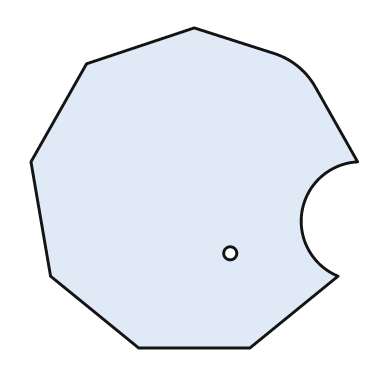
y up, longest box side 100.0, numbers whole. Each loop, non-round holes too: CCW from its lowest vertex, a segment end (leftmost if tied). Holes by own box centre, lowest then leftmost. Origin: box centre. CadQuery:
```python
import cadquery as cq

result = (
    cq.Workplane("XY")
    .moveTo(-17.0, -49.0)
    .lineTo(17.0, -49.0)
    .lineTo(44.0, -27.0)
    .threePointArc((33.0, -7.0), (50.0, 8.0))
    .lineTo(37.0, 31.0)
    .threePointArc((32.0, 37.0), (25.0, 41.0))
    .lineTo(0.0, 49.0)
    .lineTo(-33.0, 38.0)
    .lineTo(-50.0, 8.0)
    .lineTo(-44.0, -27.0)
    .close()
    .moveTo(11.0, -20.0)
    .circle(2.0)
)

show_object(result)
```